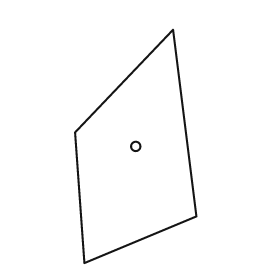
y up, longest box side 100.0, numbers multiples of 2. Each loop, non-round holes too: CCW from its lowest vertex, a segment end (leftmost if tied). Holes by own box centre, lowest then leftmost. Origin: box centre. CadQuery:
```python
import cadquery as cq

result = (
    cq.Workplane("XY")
    .moveTo(-22.0, -50.0)
    .lineTo(26.0, -30.0)
    .lineTo(16.0, 50.0)
    .lineTo(-26.0, 6.0)
    .close()
    .moveTo(0.0, 0.0)
    .circle(2.0)
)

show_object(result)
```